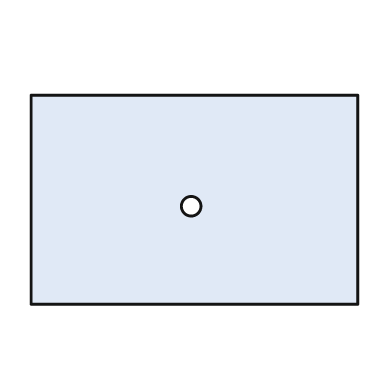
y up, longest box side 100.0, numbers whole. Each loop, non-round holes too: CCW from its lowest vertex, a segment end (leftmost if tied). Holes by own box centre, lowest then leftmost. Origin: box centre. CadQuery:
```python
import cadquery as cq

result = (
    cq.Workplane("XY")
    .moveTo(-50.0, -32.0)
    .lineTo(50.0, -32.0)
    .lineTo(50.0, 32.0)
    .lineTo(-50.0, 32.0)
    .close()
    .moveTo(-1.0, -2.0)
    .circle(3.0)
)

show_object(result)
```